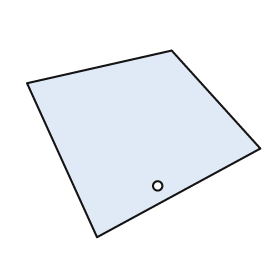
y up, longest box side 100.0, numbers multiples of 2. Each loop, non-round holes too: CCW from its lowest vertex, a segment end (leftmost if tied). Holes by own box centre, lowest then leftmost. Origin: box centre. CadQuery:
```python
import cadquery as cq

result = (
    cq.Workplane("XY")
    .moveTo(-20.0, -40.0)
    .lineTo(50.0, -2.0)
    .lineTo(12.0, 40.0)
    .lineTo(-50.0, 26.0)
    .close()
    .moveTo(6.0, -18.0)
    .circle(2.0)
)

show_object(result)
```